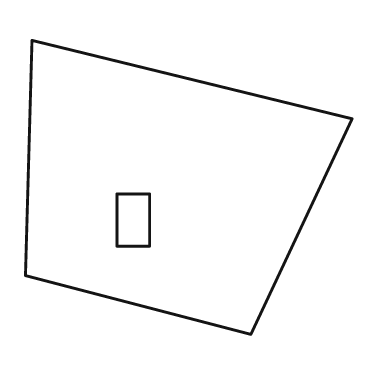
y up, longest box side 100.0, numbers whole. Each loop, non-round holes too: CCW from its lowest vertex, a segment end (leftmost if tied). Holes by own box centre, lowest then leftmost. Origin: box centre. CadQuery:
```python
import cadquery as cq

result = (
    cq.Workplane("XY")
    .moveTo(19.0, -45.0)
    .lineTo(50.0, 21.0)
    .lineTo(-48.0, 45.0)
    .lineTo(-50.0, -27.0)
    .close()
    .moveTo(-22.0, -18.0)
    .lineTo(-12.0, -18.0)
    .lineTo(-12.0, -2.0)
    .lineTo(-22.0, -2.0)
    .close()
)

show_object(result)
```